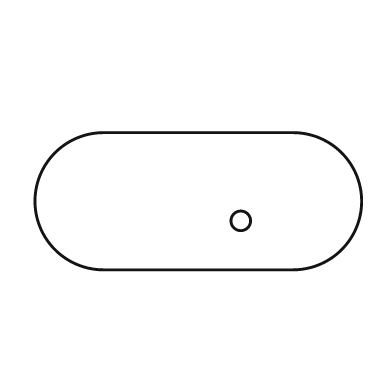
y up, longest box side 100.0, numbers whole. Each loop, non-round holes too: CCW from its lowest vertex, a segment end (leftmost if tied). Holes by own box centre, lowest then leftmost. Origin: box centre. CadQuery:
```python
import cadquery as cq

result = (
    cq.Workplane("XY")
    .moveTo(-29.0, -21.0)
    .lineTo(29.0, -21.0)
    .threePointArc((50.0, 0.0), (29.0, 21.0))
    .lineTo(-29.0, 21.0)
    .threePointArc((-50.0, 0.0), (-29.0, -21.0))
    .close()
    .moveTo(13.0, -6.0)
    .circle(3.0)
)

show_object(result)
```